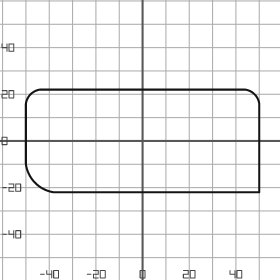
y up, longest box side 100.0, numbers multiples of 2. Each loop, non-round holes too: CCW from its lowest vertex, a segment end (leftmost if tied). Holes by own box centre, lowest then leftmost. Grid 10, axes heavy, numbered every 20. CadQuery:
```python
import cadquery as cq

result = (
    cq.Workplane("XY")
    .moveTo(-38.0, -22.0)
    .lineTo(50.0, -22.0)
    .lineTo(50.0, 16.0)
    .threePointArc((48.0, 20.0), (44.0, 22.0))
    .lineTo(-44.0, 22.0)
    .threePointArc((-48.0, 20.0), (-50.0, 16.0))
    .lineTo(-50.0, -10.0)
    .threePointArc((-46.0, -18.0), (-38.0, -22.0))
    .close()
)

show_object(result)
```